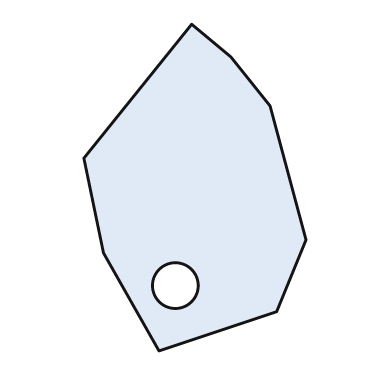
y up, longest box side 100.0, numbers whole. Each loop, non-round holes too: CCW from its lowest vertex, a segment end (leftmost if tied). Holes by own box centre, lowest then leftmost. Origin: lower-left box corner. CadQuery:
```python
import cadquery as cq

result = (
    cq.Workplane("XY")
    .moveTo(23.0, 0.0)
    .lineTo(59.0, 12.0)
    .lineTo(68.0, 34.0)
    .lineTo(57.0, 75.0)
    .lineTo(45.0, 90.0)
    .lineTo(33.0, 100.0)
    .lineTo(0.0, 59.0)
    .lineTo(6.0, 30.0)
    .close()
    .moveTo(28.0, 20.0)
    .circle(7.0)
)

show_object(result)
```